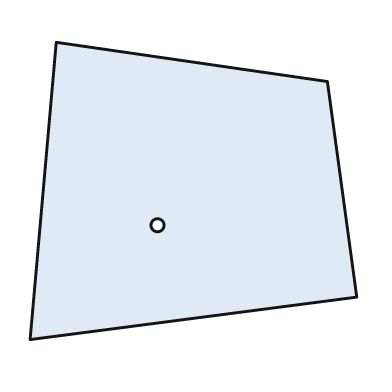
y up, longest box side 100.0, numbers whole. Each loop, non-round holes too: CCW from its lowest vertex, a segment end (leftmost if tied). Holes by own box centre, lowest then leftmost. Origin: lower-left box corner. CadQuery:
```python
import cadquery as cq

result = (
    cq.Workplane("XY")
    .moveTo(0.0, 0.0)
    .lineTo(100.0, 13.0)
    .lineTo(91.0, 79.0)
    .lineTo(8.0, 91.0)
    .close()
    .moveTo(39.0, 35.0)
    .circle(2.0)
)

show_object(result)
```